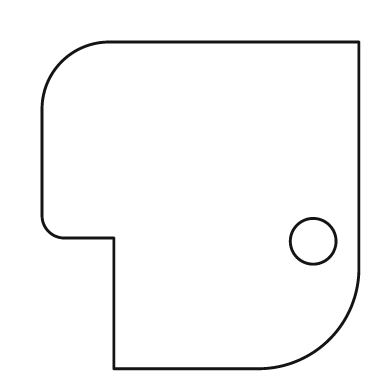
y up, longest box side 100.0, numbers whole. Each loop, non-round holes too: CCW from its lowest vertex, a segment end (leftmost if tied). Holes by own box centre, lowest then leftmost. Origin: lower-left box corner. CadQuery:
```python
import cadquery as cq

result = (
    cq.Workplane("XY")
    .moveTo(22.0, 0.0)
    .lineTo(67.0, 0.0)
    .threePointArc((88.0, 9.0), (97.0, 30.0))
    .lineTo(97.0, 100.0)
    .lineTo(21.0, 100.0)
    .threePointArc((6.0, 94.0), (0.0, 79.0))
    .lineTo(0.0, 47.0)
    .threePointArc((2.0, 42.0), (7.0, 40.0))
    .lineTo(22.0, 40.0)
    .close()
    .moveTo(83.0, 39.0)
    .circle(7.0)
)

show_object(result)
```